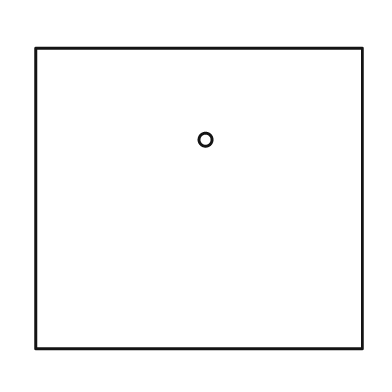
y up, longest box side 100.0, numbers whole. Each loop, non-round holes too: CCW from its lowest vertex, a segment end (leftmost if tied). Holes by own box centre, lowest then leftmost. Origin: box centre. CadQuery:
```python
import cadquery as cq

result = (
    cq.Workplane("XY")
    .moveTo(-50.0, -46.0)
    .lineTo(50.0, -46.0)
    .lineTo(50.0, 46.0)
    .lineTo(-50.0, 46.0)
    .close()
    .moveTo(2.0, 18.0)
    .circle(2.0)
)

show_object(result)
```